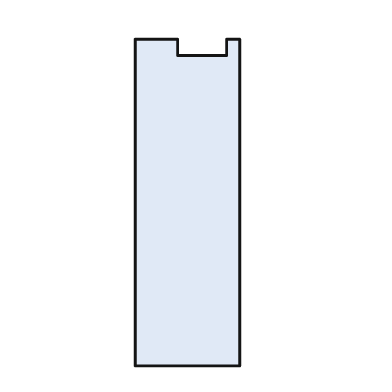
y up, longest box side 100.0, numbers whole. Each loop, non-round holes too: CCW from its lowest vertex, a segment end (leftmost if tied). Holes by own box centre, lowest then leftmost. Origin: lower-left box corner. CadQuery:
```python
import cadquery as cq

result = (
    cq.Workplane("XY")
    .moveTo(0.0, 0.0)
    .lineTo(32.0, 0.0)
    .lineTo(32.0, 100.0)
    .lineTo(28.0, 100.0)
    .lineTo(28.0, 95.0)
    .lineTo(13.0, 95.0)
    .lineTo(13.0, 100.0)
    .lineTo(0.0, 100.0)
    .close()
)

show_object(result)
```